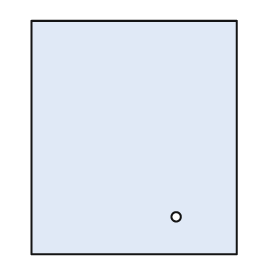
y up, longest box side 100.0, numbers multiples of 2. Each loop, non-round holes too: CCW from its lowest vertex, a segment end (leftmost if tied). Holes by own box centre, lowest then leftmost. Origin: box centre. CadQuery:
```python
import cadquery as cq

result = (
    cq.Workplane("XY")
    .moveTo(-44.0, -50.0)
    .lineTo(44.0, -50.0)
    .lineTo(44.0, 50.0)
    .lineTo(-44.0, 50.0)
    .close()
    .moveTo(18.0, -34.0)
    .circle(2.0)
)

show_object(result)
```